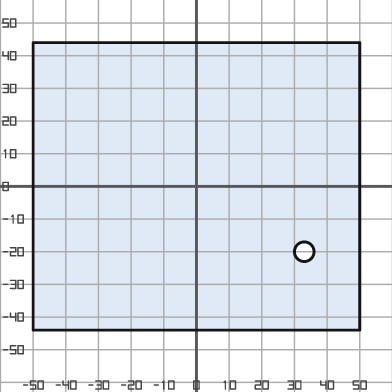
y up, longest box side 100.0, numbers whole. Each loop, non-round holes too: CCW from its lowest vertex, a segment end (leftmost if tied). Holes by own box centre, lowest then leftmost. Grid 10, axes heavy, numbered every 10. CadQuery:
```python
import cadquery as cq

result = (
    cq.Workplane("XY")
    .moveTo(-50.0, -44.0)
    .lineTo(50.0, -44.0)
    .lineTo(50.0, 44.0)
    .lineTo(-50.0, 44.0)
    .close()
    .moveTo(33.0, -20.0)
    .circle(3.0)
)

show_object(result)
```